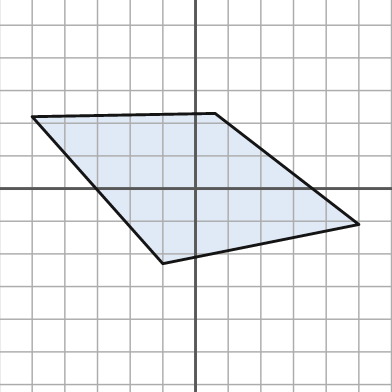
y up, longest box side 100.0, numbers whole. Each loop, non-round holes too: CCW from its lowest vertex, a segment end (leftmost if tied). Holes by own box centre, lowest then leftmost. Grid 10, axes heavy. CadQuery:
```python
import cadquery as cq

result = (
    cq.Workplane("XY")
    .moveTo(-10.0, -23.0)
    .lineTo(50.0, -11.0)
    .lineTo(6.0, 23.0)
    .lineTo(-50.0, 22.0)
    .close()
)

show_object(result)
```